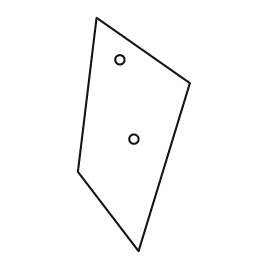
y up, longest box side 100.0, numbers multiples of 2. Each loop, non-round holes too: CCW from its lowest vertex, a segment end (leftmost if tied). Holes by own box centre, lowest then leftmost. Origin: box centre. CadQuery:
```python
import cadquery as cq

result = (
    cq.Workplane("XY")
    .moveTo(2.0, -50.0)
    .lineTo(24.0, 22.0)
    .lineTo(-16.0, 50.0)
    .lineTo(-24.0, -16.0)
    .close()
    .moveTo(0.0, -2.0)
    .circle(2.0)
    .moveTo(-6.0, 32.0)
    .circle(2.0)
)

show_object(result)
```